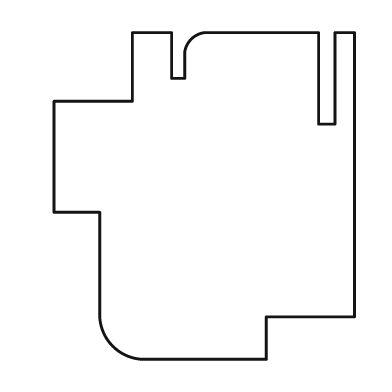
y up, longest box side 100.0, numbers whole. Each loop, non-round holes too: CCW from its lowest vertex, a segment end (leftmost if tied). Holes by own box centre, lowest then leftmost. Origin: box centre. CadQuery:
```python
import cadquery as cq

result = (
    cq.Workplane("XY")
    .moveTo(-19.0, -50.0)
    .lineTo(19.0, -50.0)
    .lineTo(19.0, -37.0)
    .lineTo(46.0, -37.0)
    .lineTo(46.0, 50.0)
    .lineTo(40.0, 50.0)
    .lineTo(40.0, 22.0)
    .lineTo(35.0, 22.0)
    .lineTo(35.0, 50.0)
    .lineTo(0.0, 50.0)
    .threePointArc((-4.0, 48.0), (-6.0, 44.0))
    .lineTo(-6.0, 36.0)
    .lineTo(-10.0, 36.0)
    .lineTo(-10.0, 50.0)
    .lineTo(-22.0, 50.0)
    .lineTo(-22.0, 29.0)
    .lineTo(-46.0, 29.0)
    .lineTo(-46.0, -5.0)
    .lineTo(-32.0, -5.0)
    .lineTo(-32.0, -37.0)
    .threePointArc((-28.0, -46.0), (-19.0, -50.0))
    .close()
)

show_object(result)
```